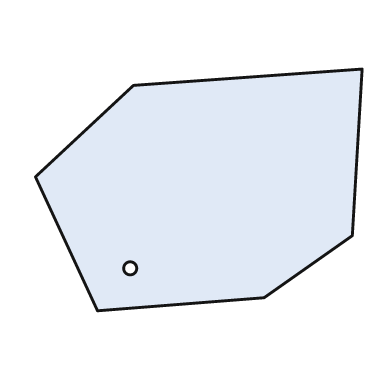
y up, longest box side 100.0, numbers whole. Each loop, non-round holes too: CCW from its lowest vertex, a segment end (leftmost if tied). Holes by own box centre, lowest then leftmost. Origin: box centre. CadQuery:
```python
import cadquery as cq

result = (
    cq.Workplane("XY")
    .moveTo(-31.0, -37.0)
    .lineTo(20.0, -33.0)
    .lineTo(47.0, -14.0)
    .lineTo(50.0, 37.0)
    .lineTo(-20.0, 32.0)
    .lineTo(-50.0, 4.0)
    .close()
    .moveTo(-21.0, -24.0)
    .circle(2.0)
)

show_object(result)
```